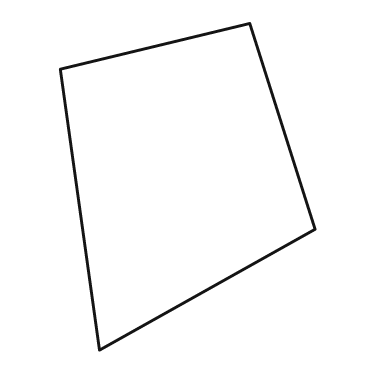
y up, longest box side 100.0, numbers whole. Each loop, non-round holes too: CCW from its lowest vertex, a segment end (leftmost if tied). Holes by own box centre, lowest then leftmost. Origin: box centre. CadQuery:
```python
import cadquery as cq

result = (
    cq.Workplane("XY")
    .moveTo(-27.0, -50.0)
    .lineTo(39.0, -13.0)
    .lineTo(19.0, 50.0)
    .lineTo(-39.0, 36.0)
    .close()
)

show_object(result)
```